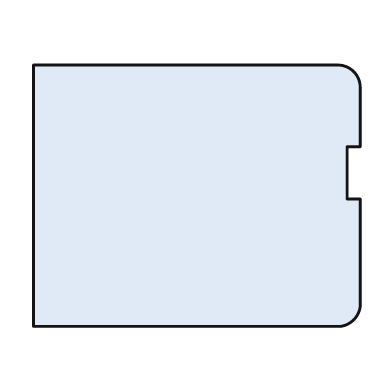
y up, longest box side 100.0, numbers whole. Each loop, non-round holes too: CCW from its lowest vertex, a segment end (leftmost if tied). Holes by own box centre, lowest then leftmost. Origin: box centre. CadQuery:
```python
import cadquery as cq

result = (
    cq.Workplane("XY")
    .moveTo(-50.0, -40.0)
    .lineTo(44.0, -40.0)
    .threePointArc((48.0, -38.0), (50.0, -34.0))
    .lineTo(50.0, -1.0)
    .lineTo(46.0, -1.0)
    .lineTo(46.0, 15.0)
    .lineTo(50.0, 15.0)
    .lineTo(50.0, 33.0)
    .threePointArc((48.0, 38.0), (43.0, 40.0))
    .lineTo(-50.0, 40.0)
    .close()
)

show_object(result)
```